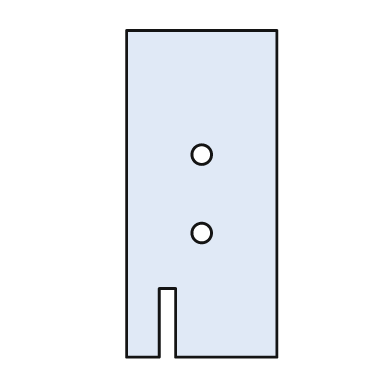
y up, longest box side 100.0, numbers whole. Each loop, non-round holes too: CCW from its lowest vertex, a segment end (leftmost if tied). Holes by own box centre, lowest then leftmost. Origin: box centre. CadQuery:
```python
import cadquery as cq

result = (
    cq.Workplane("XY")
    .moveTo(-23.0, -50.0)
    .lineTo(-13.0, -50.0)
    .lineTo(-13.0, -29.0)
    .lineTo(-8.0, -29.0)
    .lineTo(-8.0, -50.0)
    .lineTo(23.0, -50.0)
    .lineTo(23.0, 50.0)
    .lineTo(-23.0, 50.0)
    .close()
    .moveTo(0.0, -12.0)
    .circle(3.0)
    .moveTo(0.0, 12.0)
    .circle(3.0)
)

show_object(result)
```